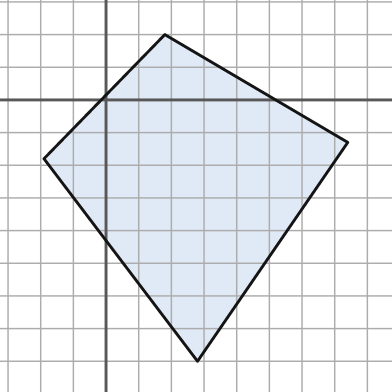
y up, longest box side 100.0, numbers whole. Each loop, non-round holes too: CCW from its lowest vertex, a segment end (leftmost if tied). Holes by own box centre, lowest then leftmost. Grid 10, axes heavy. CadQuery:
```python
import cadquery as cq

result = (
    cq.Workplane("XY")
    .moveTo(28.0, -80.0)
    .lineTo(74.0, -13.0)
    .lineTo(18.0, 20.0)
    .lineTo(-19.0, -18.0)
    .close()
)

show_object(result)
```